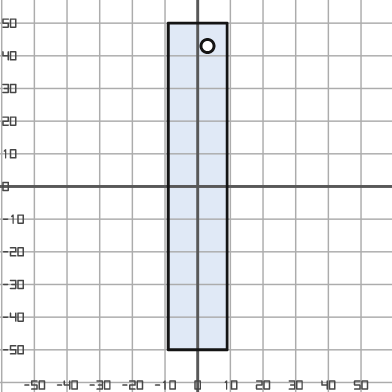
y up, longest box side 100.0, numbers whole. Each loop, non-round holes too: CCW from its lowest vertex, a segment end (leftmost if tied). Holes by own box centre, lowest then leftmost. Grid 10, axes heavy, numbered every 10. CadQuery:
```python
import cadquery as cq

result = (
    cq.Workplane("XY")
    .moveTo(-9.0, -50.0)
    .lineTo(9.0, -50.0)
    .lineTo(9.0, 50.0)
    .lineTo(-9.0, 50.0)
    .close()
    .moveTo(3.0, 43.0)
    .circle(2.0)
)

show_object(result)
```